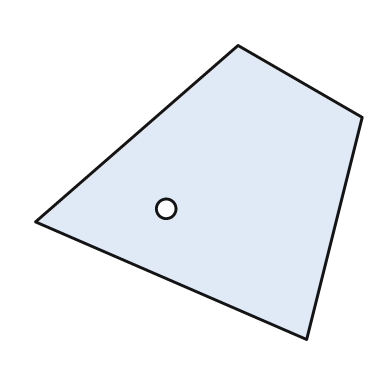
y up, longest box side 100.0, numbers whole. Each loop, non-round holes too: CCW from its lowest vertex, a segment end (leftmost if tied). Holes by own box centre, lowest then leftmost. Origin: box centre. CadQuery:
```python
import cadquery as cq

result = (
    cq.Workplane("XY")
    .moveTo(33.0, -45.0)
    .lineTo(50.0, 23.0)
    .lineTo(12.0, 45.0)
    .lineTo(-50.0, -9.0)
    .close()
    .moveTo(-10.0, -5.0)
    .circle(3.0)
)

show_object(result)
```